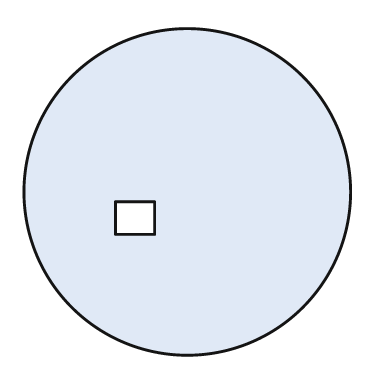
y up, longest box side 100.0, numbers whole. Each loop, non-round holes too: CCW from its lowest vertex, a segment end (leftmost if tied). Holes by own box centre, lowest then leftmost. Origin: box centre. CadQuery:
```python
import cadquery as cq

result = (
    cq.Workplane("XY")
    .moveTo(0.0, 0.0)
    .circle(50.0)
    .moveTo(-22.0, -13.0)
    .lineTo(-10.0, -13.0)
    .lineTo(-10.0, -3.0)
    .lineTo(-22.0, -3.0)
    .close()
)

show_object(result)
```